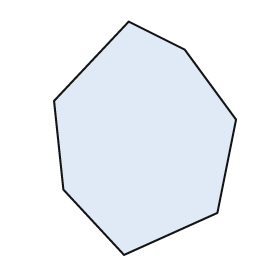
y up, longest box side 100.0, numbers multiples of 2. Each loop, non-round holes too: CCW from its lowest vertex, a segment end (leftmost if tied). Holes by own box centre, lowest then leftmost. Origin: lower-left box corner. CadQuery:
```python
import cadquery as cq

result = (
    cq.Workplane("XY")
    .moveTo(30.0, 0.0)
    .lineTo(70.0, 18.0)
    .lineTo(78.0, 58.0)
    .lineTo(56.0, 88.0)
    .lineTo(32.0, 100.0)
    .lineTo(0.0, 66.0)
    .lineTo(4.0, 28.0)
    .close()
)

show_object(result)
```